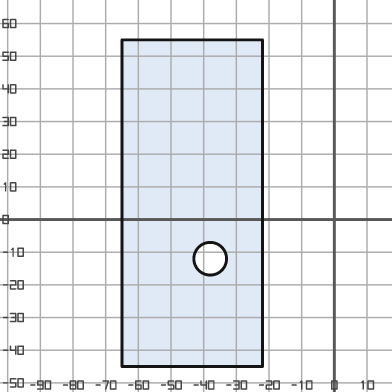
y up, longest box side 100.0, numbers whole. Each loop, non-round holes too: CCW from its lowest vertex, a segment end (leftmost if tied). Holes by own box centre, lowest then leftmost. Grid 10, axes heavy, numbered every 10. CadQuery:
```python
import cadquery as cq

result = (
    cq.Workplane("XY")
    .moveTo(-65.0, -45.0)
    .lineTo(-22.0, -45.0)
    .lineTo(-22.0, 55.0)
    .lineTo(-65.0, 55.0)
    .close()
    .moveTo(-38.0, -12.0)
    .circle(5.0)
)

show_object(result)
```